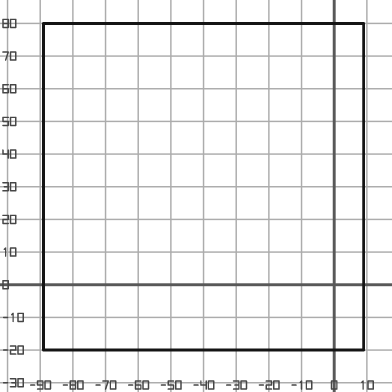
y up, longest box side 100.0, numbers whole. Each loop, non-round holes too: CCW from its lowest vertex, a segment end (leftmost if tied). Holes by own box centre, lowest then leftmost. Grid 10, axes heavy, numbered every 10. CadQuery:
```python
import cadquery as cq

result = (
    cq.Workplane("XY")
    .moveTo(-89.0, -20.0)
    .lineTo(9.0, -20.0)
    .lineTo(9.0, 80.0)
    .lineTo(-89.0, 80.0)
    .close()
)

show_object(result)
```